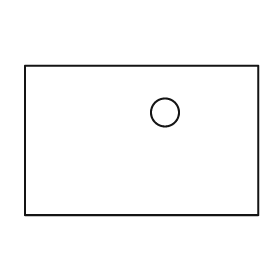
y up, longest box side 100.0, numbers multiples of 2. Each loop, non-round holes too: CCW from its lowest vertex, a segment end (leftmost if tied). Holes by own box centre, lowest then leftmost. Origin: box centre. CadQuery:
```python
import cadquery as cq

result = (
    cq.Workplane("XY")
    .moveTo(-50.0, -32.0)
    .lineTo(50.0, -32.0)
    .lineTo(50.0, 32.0)
    .lineTo(-50.0, 32.0)
    .close()
    .moveTo(10.0, 12.0)
    .circle(6.0)
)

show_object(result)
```